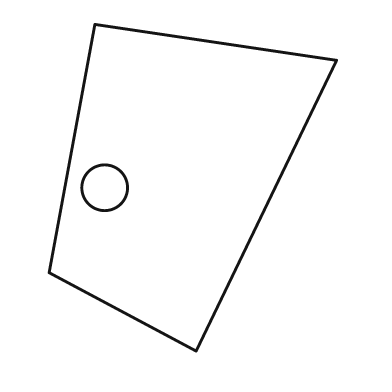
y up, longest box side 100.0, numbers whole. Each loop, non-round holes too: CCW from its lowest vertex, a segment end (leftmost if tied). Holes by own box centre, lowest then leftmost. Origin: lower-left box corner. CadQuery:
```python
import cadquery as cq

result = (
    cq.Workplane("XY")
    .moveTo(45.0, 0.0)
    .lineTo(88.0, 89.0)
    .lineTo(14.0, 100.0)
    .lineTo(0.0, 24.0)
    .close()
    .moveTo(17.0, 50.0)
    .circle(7.0)
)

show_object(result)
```